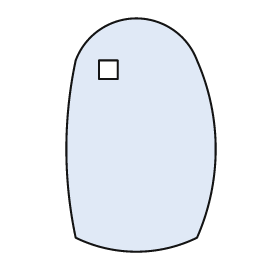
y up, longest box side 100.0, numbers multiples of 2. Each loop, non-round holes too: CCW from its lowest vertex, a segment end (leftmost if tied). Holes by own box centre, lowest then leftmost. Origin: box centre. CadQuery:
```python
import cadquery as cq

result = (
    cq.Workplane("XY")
    .moveTo(-28.0, -44.0)
    .threePointArc((-2.0, -50.0), (24.0, -44.0))
    .threePointArc((32.0, -6.0), (24.0, 32.0))
    .threePointArc((-2.0, 50.0), (-28.0, 32.0))
    .threePointArc((-32.0, -6.0), (-28.0, -44.0))
    .close()
    .moveTo(-18.0, 24.0)
    .lineTo(-10.0, 24.0)
    .lineTo(-10.0, 32.0)
    .lineTo(-18.0, 32.0)
    .close()
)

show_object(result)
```